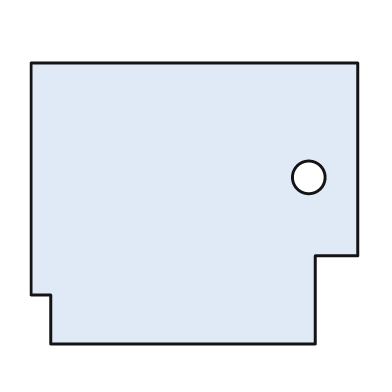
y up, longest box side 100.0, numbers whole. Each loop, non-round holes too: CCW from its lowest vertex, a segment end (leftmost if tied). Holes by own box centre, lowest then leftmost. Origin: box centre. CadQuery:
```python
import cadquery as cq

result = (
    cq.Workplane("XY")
    .moveTo(-44.0, -43.0)
    .lineTo(37.0, -43.0)
    .lineTo(37.0, -16.0)
    .lineTo(50.0, -16.0)
    .lineTo(50.0, 43.0)
    .lineTo(-50.0, 43.0)
    .lineTo(-50.0, -28.0)
    .lineTo(-44.0, -28.0)
    .close()
    .moveTo(35.0, 8.0)
    .circle(5.0)
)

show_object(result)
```